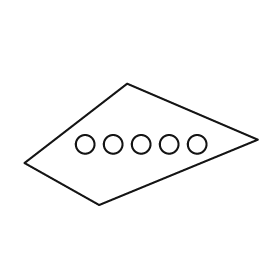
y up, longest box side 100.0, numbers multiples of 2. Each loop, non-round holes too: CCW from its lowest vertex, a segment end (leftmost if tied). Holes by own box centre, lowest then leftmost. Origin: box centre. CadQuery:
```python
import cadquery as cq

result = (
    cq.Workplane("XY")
    .moveTo(-18.0, -26.0)
    .lineTo(50.0, 2.0)
    .lineTo(-6.0, 26.0)
    .lineTo(-50.0, -8.0)
    .close()
    .moveTo(-24.0, 0.0)
    .circle(4.0)
    .moveTo(-12.0, 0.0)
    .circle(4.0)
    .moveTo(0.0, 0.0)
    .circle(4.0)
    .moveTo(12.0, 0.0)
    .circle(4.0)
    .moveTo(24.0, 0.0)
    .circle(4.0)
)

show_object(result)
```